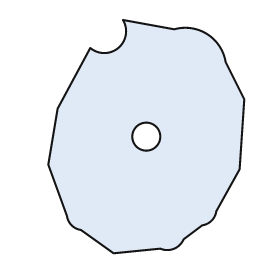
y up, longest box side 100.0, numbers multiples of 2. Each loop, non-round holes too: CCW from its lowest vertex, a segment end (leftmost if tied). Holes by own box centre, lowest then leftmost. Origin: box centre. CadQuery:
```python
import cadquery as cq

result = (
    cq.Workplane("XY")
    .moveTo(-14.0, -50.0)
    .lineTo(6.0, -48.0)
    .threePointArc((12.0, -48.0), (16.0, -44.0))
    .lineTo(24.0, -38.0)
    .threePointArc((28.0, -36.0), (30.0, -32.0))
    .lineTo(40.0, -14.0)
    .lineTo(42.0, 16.0)
    .lineTo(34.0, 32.0)
    .threePointArc((26.0, 44.0), (12.0, 46.0))
    .lineTo(-10.0, 50.0)
    .threePointArc((-12.0, 38.0), (-24.0, 38.0))
    .lineTo(-38.0, 12.0)
    .lineTo(-42.0, -12.0)
    .lineTo(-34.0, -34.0)
    .threePointArc((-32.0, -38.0), (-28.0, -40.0))
    .close()
    .moveTo(0.0, 0.0)
    .circle(6.0)
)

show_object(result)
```